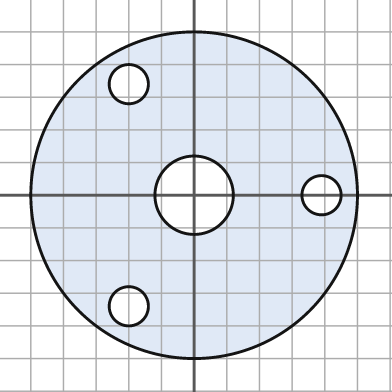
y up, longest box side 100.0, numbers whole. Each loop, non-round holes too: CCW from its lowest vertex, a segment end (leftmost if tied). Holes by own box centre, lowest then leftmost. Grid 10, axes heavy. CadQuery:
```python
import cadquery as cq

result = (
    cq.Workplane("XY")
    .moveTo(0.0, 0.0)
    .circle(50.0)
    .moveTo(-20.0, -34.0)
    .circle(6.0)
    .moveTo(0.0, 0.0)
    .circle(12.0)
    .moveTo(39.0, 0.0)
    .circle(6.0)
    .moveTo(-20.0, 34.0)
    .circle(6.0)
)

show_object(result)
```